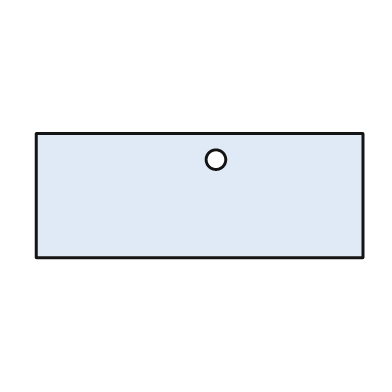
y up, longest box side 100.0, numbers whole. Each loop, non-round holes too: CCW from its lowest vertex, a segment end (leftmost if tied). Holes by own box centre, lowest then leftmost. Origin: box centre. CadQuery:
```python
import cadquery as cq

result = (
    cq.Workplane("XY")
    .moveTo(-50.0, -19.0)
    .lineTo(50.0, -19.0)
    .lineTo(50.0, 19.0)
    .lineTo(-50.0, 19.0)
    .close()
    .moveTo(5.0, 11.0)
    .circle(3.0)
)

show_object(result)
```